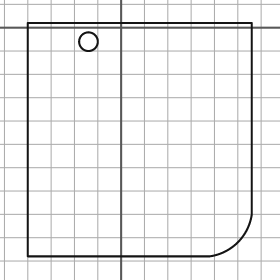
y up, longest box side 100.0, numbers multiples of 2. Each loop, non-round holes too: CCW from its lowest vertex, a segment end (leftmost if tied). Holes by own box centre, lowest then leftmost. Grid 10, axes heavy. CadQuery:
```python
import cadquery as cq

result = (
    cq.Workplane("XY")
    .moveTo(-40.0, -98.0)
    .lineTo(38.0, -98.0)
    .threePointArc((50.0, -92.0), (56.0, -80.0))
    .lineTo(56.0, 2.0)
    .lineTo(-40.0, 2.0)
    .close()
    .moveTo(-14.0, -6.0)
    .circle(4.0)
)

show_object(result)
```